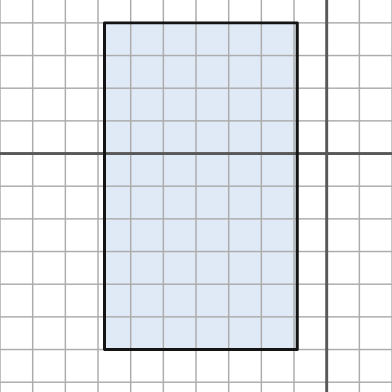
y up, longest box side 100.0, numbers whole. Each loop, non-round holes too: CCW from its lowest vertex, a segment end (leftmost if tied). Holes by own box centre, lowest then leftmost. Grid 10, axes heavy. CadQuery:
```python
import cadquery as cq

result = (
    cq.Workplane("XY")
    .moveTo(-68.0, -60.0)
    .lineTo(-9.0, -60.0)
    .lineTo(-9.0, 40.0)
    .lineTo(-68.0, 40.0)
    .close()
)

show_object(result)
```